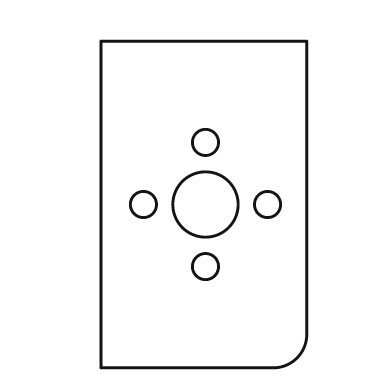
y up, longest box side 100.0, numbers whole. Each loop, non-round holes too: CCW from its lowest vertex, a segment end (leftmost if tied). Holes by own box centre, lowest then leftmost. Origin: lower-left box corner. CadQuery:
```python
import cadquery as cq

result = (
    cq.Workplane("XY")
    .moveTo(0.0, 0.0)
    .lineTo(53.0, 0.0)
    .threePointArc((60.0, 3.0), (63.0, 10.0))
    .lineTo(63.0, 100.0)
    .lineTo(0.0, 100.0)
    .close()
    .moveTo(32.0, 31.0)
    .circle(4.0)
    .moveTo(13.0, 50.0)
    .circle(4.0)
    .moveTo(32.0, 50.0)
    .circle(10.0)
    .moveTo(51.0, 50.0)
    .circle(4.0)
    .moveTo(32.0, 69.0)
    .circle(4.0)
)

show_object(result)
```